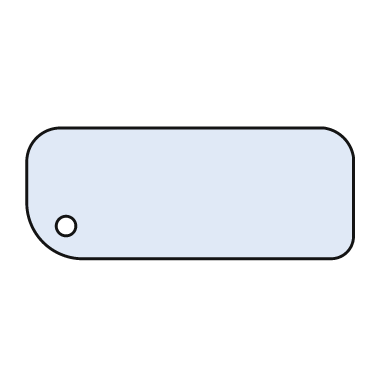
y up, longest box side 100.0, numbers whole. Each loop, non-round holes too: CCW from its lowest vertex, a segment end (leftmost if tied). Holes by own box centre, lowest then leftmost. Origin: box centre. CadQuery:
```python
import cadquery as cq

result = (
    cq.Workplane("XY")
    .moveTo(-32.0, -20.0)
    .lineTo(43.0, -20.0)
    .threePointArc((48.0, -18.0), (50.0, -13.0))
    .lineTo(50.0, 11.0)
    .threePointArc((47.0, 17.0), (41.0, 20.0))
    .lineTo(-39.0, 20.0)
    .threePointArc((-47.0, 17.0), (-50.0, 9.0))
    .lineTo(-50.0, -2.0)
    .threePointArc((-45.0, -15.0), (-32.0, -20.0))
    .close()
    .moveTo(-38.0, -10.0)
    .circle(3.0)
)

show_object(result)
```